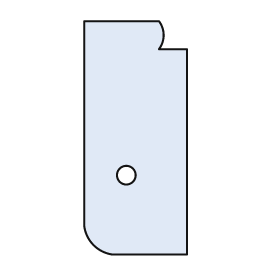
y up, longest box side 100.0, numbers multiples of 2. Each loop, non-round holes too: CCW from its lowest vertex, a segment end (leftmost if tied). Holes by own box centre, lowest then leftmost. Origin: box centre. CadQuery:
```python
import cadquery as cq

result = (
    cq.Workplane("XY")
    .moveTo(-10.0, -50.0)
    .lineTo(22.0, -50.0)
    .lineTo(22.0, 38.0)
    .lineTo(10.0, 38.0)
    .threePointArc((12.0, 44.0), (10.0, 50.0))
    .lineTo(-22.0, 50.0)
    .lineTo(-22.0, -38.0)
    .threePointArc((-18.0, -46.0), (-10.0, -50.0))
    .close()
    .moveTo(-4.0, -16.0)
    .circle(4.0)
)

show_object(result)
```